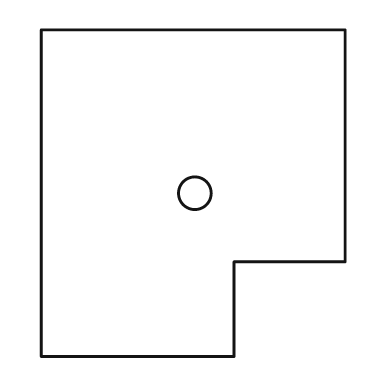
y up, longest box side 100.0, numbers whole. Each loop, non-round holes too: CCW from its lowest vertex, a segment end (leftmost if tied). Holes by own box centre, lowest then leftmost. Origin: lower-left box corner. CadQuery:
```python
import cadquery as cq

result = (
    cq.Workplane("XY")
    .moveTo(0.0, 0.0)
    .lineTo(59.0, 0.0)
    .lineTo(59.0, 29.0)
    .lineTo(93.0, 29.0)
    .lineTo(93.0, 100.0)
    .lineTo(0.0, 100.0)
    .close()
    .moveTo(47.0, 50.0)
    .circle(5.0)
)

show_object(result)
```